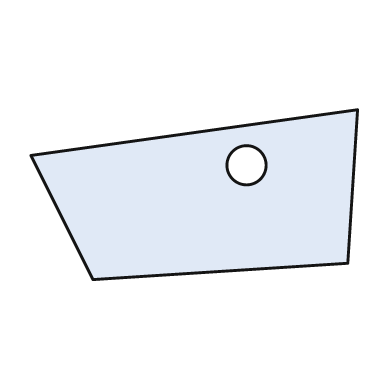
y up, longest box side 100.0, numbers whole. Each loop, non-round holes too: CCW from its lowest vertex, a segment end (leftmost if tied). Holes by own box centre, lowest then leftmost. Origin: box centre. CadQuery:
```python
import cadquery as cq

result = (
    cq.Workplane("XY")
    .moveTo(-31.0, -26.0)
    .lineTo(47.0, -21.0)
    .lineTo(50.0, 26.0)
    .lineTo(-50.0, 12.0)
    .close()
    .moveTo(16.0, 9.0)
    .circle(6.0)
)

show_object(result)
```